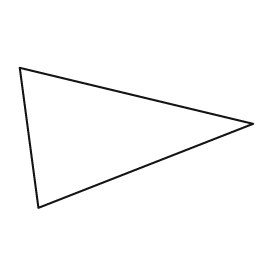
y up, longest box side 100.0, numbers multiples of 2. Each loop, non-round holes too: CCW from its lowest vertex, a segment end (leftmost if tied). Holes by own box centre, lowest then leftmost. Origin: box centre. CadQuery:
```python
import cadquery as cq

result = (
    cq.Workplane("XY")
    .moveTo(-42.0, -30.0)
    .lineTo(50.0, 6.0)
    .lineTo(-50.0, 30.0)
    .close()
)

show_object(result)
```